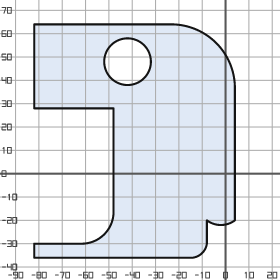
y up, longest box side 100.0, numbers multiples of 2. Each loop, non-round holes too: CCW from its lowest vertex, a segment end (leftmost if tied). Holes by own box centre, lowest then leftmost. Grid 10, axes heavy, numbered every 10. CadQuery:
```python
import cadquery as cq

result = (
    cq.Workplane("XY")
    .moveTo(-82.0, -36.0)
    .lineTo(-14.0, -36.0)
    .threePointArc((-10.0, -34.0), (-8.0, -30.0))
    .lineTo(-8.0, -20.0)
    .threePointArc((-2.0, -22.0), (4.0, -20.0))
    .lineTo(4.0, 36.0)
    .threePointArc((-4.0, 56.0), (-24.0, 64.0))
    .lineTo(-82.0, 64.0)
    .lineTo(-82.0, 28.0)
    .lineTo(-48.0, 28.0)
    .lineTo(-48.0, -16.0)
    .threePointArc((-52.0, -26.0), (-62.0, -30.0))
    .lineTo(-82.0, -30.0)
    .close()
    .moveTo(-42.0, 48.0)
    .circle(10.0)
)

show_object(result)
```